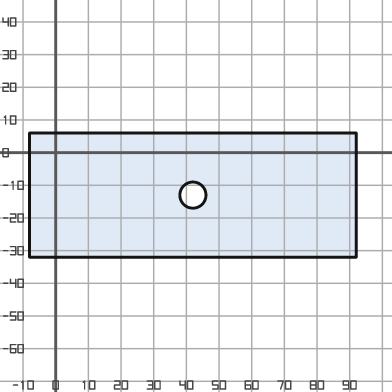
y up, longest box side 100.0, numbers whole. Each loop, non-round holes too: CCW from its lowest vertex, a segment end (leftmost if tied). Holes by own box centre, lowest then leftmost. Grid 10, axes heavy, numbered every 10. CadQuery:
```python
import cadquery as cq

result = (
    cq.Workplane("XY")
    .moveTo(-8.0, -32.0)
    .lineTo(92.0, -32.0)
    .lineTo(92.0, 6.0)
    .lineTo(-8.0, 6.0)
    .close()
    .moveTo(42.0, -13.0)
    .circle(4.0)
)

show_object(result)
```